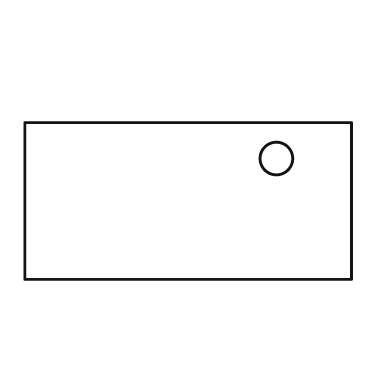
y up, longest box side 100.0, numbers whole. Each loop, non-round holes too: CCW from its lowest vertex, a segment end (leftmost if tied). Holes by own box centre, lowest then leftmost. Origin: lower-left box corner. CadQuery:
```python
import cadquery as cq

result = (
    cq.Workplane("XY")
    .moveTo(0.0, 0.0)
    .lineTo(100.0, 0.0)
    .lineTo(100.0, 48.0)
    .lineTo(0.0, 48.0)
    .close()
    .moveTo(77.0, 37.0)
    .circle(5.0)
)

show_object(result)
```